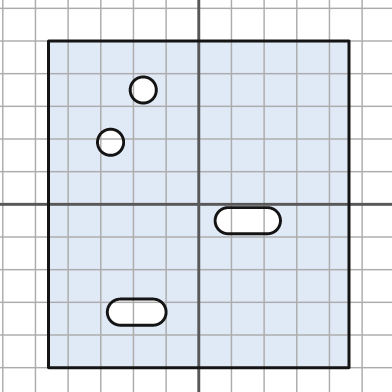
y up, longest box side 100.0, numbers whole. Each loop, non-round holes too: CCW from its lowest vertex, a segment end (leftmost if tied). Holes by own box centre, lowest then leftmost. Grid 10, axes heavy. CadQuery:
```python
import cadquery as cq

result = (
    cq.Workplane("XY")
    .moveTo(-46.0, -50.0)
    .lineTo(46.0, -50.0)
    .lineTo(46.0, 50.0)
    .lineTo(-46.0, 50.0)
    .close()
    .moveTo(-24.0, -37.0)
    .lineTo(-14.0, -37.0)
    .threePointArc((-10.0, -33.0), (-14.0, -29.0))
    .lineTo(-24.0, -29.0)
    .threePointArc((-28.0, -33.0), (-24.0, -37.0))
    .close()
    .moveTo(9.0, -9.0)
    .lineTo(21.0, -9.0)
    .threePointArc((25.0, -5.0), (21.0, -1.0))
    .lineTo(9.0, -1.0)
    .threePointArc((5.0, -5.0), (9.0, -9.0))
    .close()
    .moveTo(-27.0, 19.0)
    .circle(4.0)
    .moveTo(-17.0, 35.0)
    .circle(4.0)
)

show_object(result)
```